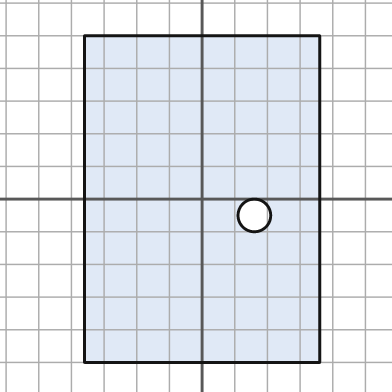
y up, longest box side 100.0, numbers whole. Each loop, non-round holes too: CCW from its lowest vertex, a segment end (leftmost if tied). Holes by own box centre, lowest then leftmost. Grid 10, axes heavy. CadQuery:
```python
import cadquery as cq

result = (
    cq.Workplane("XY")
    .moveTo(-36.0, -50.0)
    .lineTo(36.0, -50.0)
    .lineTo(36.0, 50.0)
    .lineTo(-36.0, 50.0)
    .close()
    .moveTo(16.0, -5.0)
    .circle(5.0)
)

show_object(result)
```